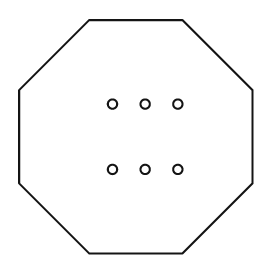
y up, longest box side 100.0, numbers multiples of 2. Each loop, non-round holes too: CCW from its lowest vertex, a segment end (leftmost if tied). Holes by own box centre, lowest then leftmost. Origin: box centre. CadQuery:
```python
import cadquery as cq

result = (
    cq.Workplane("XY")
    .moveTo(-20.0, -50.0)
    .lineTo(20.0, -50.0)
    .lineTo(50.0, -20.0)
    .lineTo(50.0, 20.0)
    .lineTo(20.0, 50.0)
    .lineTo(-20.0, 50.0)
    .lineTo(-50.0, 20.0)
    .lineTo(-50.0, -20.0)
    .close()
    .moveTo(-10.0, -14.0)
    .circle(2.0)
    .moveTo(4.0, -14.0)
    .circle(2.0)
    .moveTo(18.0, -14.0)
    .circle(2.0)
    .moveTo(-10.0, 14.0)
    .circle(2.0)
    .moveTo(4.0, 14.0)
    .circle(2.0)
    .moveTo(18.0, 14.0)
    .circle(2.0)
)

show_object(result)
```